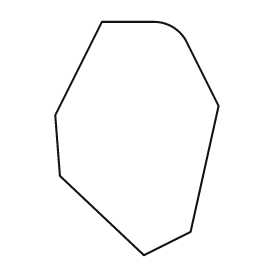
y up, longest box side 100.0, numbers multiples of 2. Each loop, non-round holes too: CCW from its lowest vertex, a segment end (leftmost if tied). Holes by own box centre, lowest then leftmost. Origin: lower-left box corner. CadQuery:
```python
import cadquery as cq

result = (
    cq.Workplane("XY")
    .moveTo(38.0, 0.0)
    .lineTo(58.0, 10.0)
    .lineTo(70.0, 64.0)
    .lineTo(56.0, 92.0)
    .threePointArc((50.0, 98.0), (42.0, 100.0))
    .lineTo(20.0, 100.0)
    .lineTo(0.0, 60.0)
    .lineTo(2.0, 34.0)
    .close()
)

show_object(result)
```